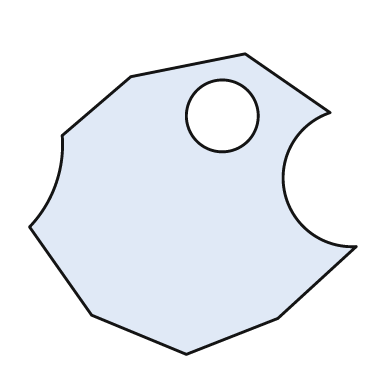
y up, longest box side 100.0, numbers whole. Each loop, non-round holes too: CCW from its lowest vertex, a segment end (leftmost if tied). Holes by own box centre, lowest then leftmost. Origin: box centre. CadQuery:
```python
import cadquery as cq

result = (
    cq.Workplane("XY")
    .moveTo(-2.0, -46.0)
    .lineTo(26.0, -35.0)
    .lineTo(50.0, -13.0)
    .threePointArc((28.0, 4.0), (42.0, 28.0))
    .lineTo(16.0, 46.0)
    .lineTo(-19.0, 39.0)
    .lineTo(-40.0, 21.0)
    .threePointArc((-42.0, 6.0), (-50.0, -7.0))
    .lineTo(-31.0, -34.0)
    .close()
    .moveTo(9.0, 27.0)
    .circle(11.0)
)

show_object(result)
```